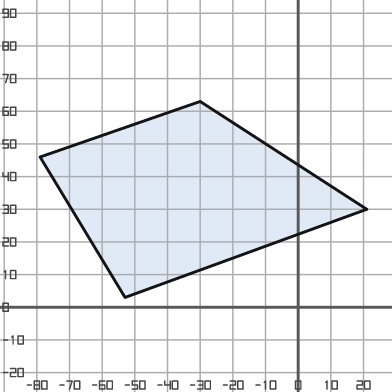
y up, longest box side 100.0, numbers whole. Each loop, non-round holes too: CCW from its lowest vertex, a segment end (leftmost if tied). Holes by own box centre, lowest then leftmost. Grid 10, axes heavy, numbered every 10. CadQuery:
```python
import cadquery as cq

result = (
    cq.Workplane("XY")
    .moveTo(-53.0, 3.0)
    .lineTo(21.0, 30.0)
    .lineTo(-30.0, 63.0)
    .lineTo(-79.0, 46.0)
    .close()
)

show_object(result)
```